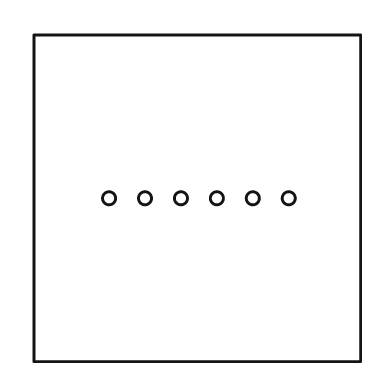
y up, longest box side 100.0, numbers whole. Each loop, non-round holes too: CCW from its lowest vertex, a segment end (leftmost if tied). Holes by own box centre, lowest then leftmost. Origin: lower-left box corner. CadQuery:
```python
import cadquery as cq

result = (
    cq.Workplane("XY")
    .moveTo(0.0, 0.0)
    .lineTo(100.0, 0.0)
    .lineTo(100.0, 100.0)
    .lineTo(0.0, 100.0)
    .close()
    .moveTo(23.0, 50.0)
    .circle(2.0)
    .moveTo(34.0, 50.0)
    .circle(2.0)
    .moveTo(45.0, 50.0)
    .circle(2.0)
    .moveTo(56.0, 50.0)
    .circle(2.0)
    .moveTo(67.0, 50.0)
    .circle(2.0)
    .moveTo(78.0, 50.0)
    .circle(2.0)
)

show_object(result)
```